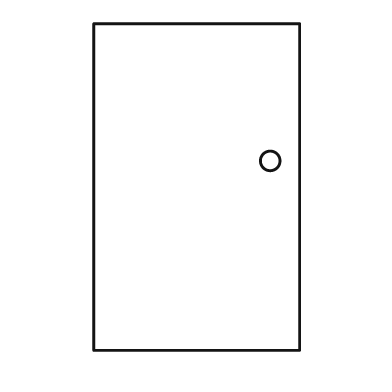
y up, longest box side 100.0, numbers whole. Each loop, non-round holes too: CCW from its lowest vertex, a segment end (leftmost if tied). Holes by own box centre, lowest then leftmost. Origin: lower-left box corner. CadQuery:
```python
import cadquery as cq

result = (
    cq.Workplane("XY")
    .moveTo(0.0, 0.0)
    .lineTo(63.0, 0.0)
    .lineTo(63.0, 100.0)
    .lineTo(0.0, 100.0)
    .close()
    .moveTo(54.0, 58.0)
    .circle(3.0)
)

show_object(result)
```